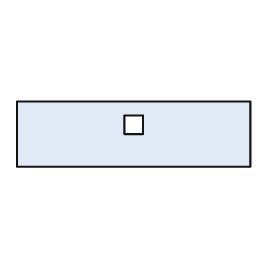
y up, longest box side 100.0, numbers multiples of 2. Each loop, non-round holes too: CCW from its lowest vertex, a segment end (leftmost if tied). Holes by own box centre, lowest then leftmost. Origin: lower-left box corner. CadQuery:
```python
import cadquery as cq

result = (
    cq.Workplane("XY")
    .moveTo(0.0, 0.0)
    .lineTo(100.0, 0.0)
    .lineTo(100.0, 28.0)
    .lineTo(0.0, 28.0)
    .close()
    .moveTo(46.0, 14.0)
    .lineTo(54.0, 14.0)
    .lineTo(54.0, 22.0)
    .lineTo(46.0, 22.0)
    .close()
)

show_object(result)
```